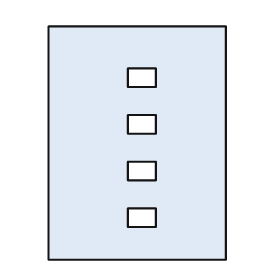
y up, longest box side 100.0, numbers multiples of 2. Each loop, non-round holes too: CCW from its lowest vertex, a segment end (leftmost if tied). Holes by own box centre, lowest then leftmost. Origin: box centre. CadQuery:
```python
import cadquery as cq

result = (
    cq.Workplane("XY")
    .moveTo(-38.0, -50.0)
    .lineTo(38.0, -50.0)
    .lineTo(38.0, 50.0)
    .lineTo(-38.0, 50.0)
    .close()
    .moveTo(-4.0, -36.0)
    .lineTo(8.0, -36.0)
    .lineTo(8.0, -28.0)
    .lineTo(-4.0, -28.0)
    .close()
    .moveTo(-4.0, -16.0)
    .lineTo(8.0, -16.0)
    .lineTo(8.0, -8.0)
    .lineTo(-4.0, -8.0)
    .close()
    .moveTo(-4.0, 4.0)
    .lineTo(8.0, 4.0)
    .lineTo(8.0, 12.0)
    .lineTo(-4.0, 12.0)
    .close()
    .moveTo(-4.0, 24.0)
    .lineTo(8.0, 24.0)
    .lineTo(8.0, 32.0)
    .lineTo(-4.0, 32.0)
    .close()
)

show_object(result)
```